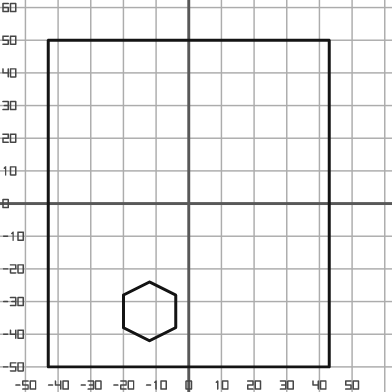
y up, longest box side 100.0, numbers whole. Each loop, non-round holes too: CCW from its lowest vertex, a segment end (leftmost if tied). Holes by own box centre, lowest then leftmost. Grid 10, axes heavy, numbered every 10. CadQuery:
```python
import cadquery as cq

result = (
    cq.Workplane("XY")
    .moveTo(-43.0, -50.0)
    .lineTo(43.0, -50.0)
    .lineTo(43.0, 50.0)
    .lineTo(-43.0, 50.0)
    .close()
    .moveTo(-12.0, -42.0)
    .lineTo(-4.0, -38.0)
    .lineTo(-4.0, -28.0)
    .lineTo(-12.0, -24.0)
    .lineTo(-20.0, -28.0)
    .lineTo(-20.0, -38.0)
    .close()
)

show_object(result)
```